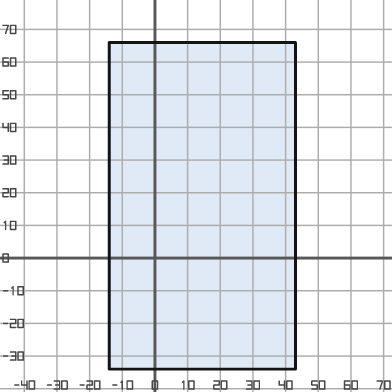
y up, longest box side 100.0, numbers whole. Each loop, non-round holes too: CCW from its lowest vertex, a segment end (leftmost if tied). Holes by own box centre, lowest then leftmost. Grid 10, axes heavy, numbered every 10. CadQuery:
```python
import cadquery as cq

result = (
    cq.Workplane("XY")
    .moveTo(-14.0, -34.0)
    .lineTo(43.0, -34.0)
    .lineTo(43.0, 66.0)
    .lineTo(-14.0, 66.0)
    .close()
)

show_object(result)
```